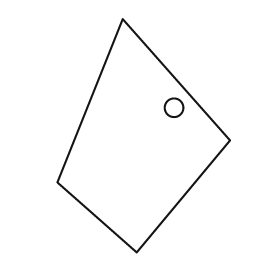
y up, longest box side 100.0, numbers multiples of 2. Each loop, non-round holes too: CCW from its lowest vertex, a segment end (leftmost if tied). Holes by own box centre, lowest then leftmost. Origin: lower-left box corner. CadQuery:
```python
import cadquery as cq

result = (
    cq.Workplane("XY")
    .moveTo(34.0, 0.0)
    .lineTo(74.0, 48.0)
    .lineTo(28.0, 100.0)
    .lineTo(0.0, 30.0)
    .close()
    .moveTo(50.0, 62.0)
    .circle(4.0)
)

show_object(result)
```